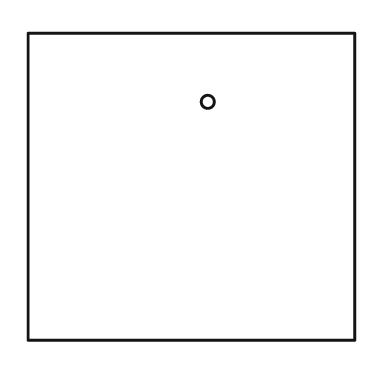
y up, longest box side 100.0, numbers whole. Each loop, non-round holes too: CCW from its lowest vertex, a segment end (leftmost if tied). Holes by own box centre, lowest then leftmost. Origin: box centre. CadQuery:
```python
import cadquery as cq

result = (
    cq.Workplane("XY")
    .moveTo(-50.0, -47.0)
    .lineTo(50.0, -47.0)
    .lineTo(50.0, 47.0)
    .lineTo(-50.0, 47.0)
    .close()
    .moveTo(5.0, 26.0)
    .circle(2.0)
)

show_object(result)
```